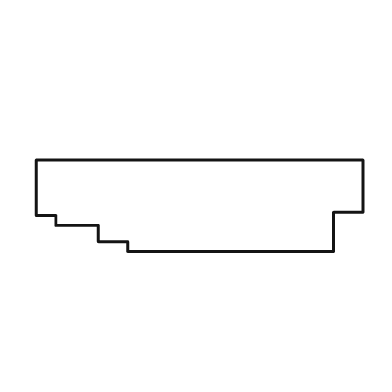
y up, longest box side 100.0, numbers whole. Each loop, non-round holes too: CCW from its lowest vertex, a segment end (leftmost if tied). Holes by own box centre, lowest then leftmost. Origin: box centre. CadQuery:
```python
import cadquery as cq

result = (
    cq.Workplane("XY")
    .moveTo(-22.0, -14.0)
    .lineTo(41.0, -14.0)
    .lineTo(41.0, -2.0)
    .lineTo(50.0, -2.0)
    .lineTo(50.0, 14.0)
    .lineTo(-50.0, 14.0)
    .lineTo(-50.0, -3.0)
    .lineTo(-44.0, -3.0)
    .lineTo(-44.0, -6.0)
    .lineTo(-31.0, -6.0)
    .lineTo(-31.0, -11.0)
    .lineTo(-22.0, -11.0)
    .close()
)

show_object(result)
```